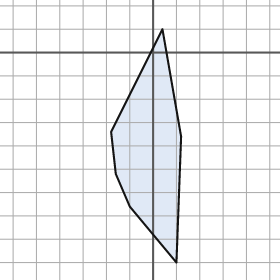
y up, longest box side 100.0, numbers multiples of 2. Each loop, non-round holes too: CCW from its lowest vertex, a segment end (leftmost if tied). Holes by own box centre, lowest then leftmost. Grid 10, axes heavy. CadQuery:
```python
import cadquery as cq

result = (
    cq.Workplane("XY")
    .moveTo(10.0, -90.0)
    .lineTo(12.0, -36.0)
    .lineTo(4.0, 10.0)
    .lineTo(-18.0, -34.0)
    .lineTo(-16.0, -52.0)
    .lineTo(-10.0, -66.0)
    .close()
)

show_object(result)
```